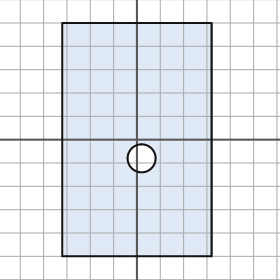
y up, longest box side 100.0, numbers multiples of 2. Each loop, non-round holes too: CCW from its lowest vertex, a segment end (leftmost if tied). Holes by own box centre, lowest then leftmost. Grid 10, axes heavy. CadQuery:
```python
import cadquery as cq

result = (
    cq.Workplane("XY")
    .moveTo(-32.0, -50.0)
    .lineTo(32.0, -50.0)
    .lineTo(32.0, 50.0)
    .lineTo(-32.0, 50.0)
    .close()
    .moveTo(2.0, -8.0)
    .circle(6.0)
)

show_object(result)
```